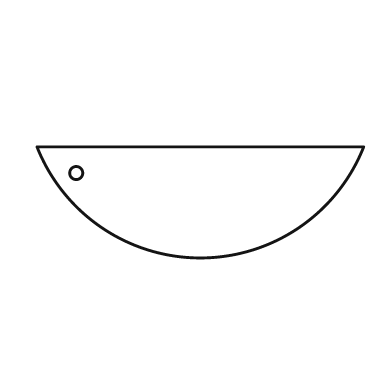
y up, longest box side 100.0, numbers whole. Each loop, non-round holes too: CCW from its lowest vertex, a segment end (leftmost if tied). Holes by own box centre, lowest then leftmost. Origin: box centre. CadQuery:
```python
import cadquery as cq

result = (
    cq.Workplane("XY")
    .moveTo(-50.0, 17.0)
    .threePointArc((0.0, -17.0), (50.0, 17.0))
    .close()
    .moveTo(-38.0, 9.0)
    .circle(2.0)
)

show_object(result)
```